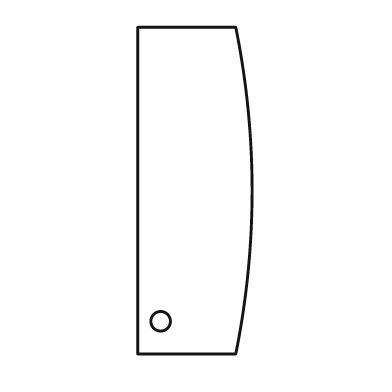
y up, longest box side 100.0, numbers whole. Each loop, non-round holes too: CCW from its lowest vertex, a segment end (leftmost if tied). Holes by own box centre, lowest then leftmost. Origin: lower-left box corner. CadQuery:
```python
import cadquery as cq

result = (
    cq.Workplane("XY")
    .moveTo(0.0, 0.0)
    .lineTo(30.0, 0.0)
    .threePointArc((35.0, 50.0), (30.0, 100.0))
    .lineTo(0.0, 100.0)
    .close()
    .moveTo(7.0, 10.0)
    .circle(3.0)
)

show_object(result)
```